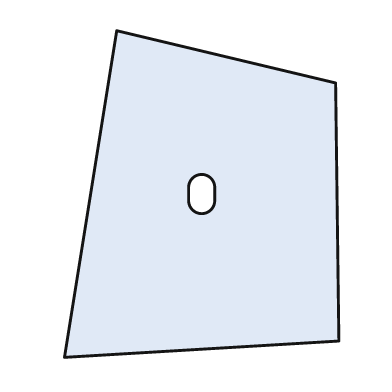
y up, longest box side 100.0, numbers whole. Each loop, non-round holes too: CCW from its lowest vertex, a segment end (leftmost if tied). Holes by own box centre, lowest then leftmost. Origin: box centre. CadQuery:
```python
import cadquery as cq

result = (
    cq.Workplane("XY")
    .moveTo(-42.0, -50.0)
    .lineTo(42.0, -45.0)
    .lineTo(41.0, 34.0)
    .lineTo(-26.0, 50.0)
    .close()
    .moveTo(-4.0, -2.0)
    .threePointArc((0.0, -6.0), (4.0, -2.0))
    .lineTo(4.0, 2.0)
    .threePointArc((0.0, 6.0), (-4.0, 2.0))
    .close()
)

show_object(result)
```